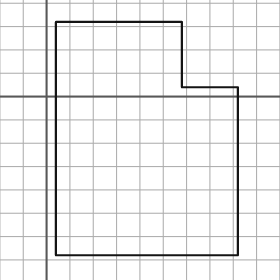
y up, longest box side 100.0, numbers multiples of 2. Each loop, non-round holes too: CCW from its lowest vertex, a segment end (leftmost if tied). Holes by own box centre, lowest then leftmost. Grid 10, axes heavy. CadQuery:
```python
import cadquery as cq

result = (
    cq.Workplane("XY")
    .moveTo(4.0, -68.0)
    .lineTo(82.0, -68.0)
    .lineTo(82.0, 4.0)
    .lineTo(58.0, 4.0)
    .lineTo(58.0, 32.0)
    .lineTo(4.0, 32.0)
    .close()
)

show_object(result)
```